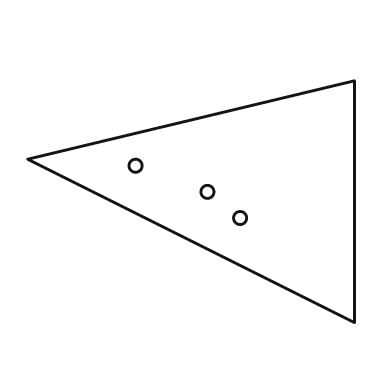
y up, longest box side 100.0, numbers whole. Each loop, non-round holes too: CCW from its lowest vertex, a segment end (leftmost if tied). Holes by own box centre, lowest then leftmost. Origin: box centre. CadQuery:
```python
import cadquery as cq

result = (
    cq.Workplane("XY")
    .moveTo(50.0, -37.0)
    .lineTo(50.0, 37.0)
    .lineTo(-50.0, 13.0)
    .close()
    .moveTo(15.0, -5.0)
    .circle(2.0)
    .moveTo(5.0, 3.0)
    .circle(2.0)
    .moveTo(-17.0, 11.0)
    .circle(2.0)
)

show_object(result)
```